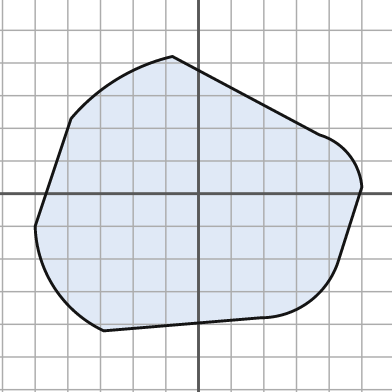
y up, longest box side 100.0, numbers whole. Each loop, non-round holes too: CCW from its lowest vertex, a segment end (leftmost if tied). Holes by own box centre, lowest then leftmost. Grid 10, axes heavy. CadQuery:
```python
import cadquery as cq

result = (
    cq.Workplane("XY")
    .moveTo(-29.0, -42.0)
    .lineTo(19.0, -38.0)
    .threePointArc((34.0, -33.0), (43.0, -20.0))
    .lineTo(50.0, 2.0)
    .threePointArc((46.0, 12.0), (37.0, 18.0))
    .lineTo(-8.0, 42.0)
    .threePointArc((-25.0, 35.0), (-39.0, 23.0))
    .lineTo(-50.0, -10.0)
    .threePointArc((-44.0, -29.0), (-29.0, -42.0))
    .close()
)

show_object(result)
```